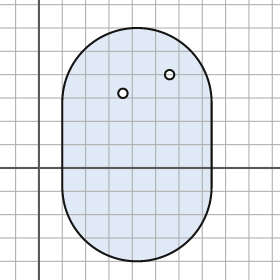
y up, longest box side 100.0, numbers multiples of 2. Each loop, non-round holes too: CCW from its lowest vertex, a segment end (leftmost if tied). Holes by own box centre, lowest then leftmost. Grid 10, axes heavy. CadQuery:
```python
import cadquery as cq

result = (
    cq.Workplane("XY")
    .moveTo(10.0, -8.0)
    .threePointArc((42.0, -40.0), (74.0, -8.0))
    .lineTo(74.0, 28.0)
    .threePointArc((42.0, 60.0), (10.0, 28.0))
    .close()
    .moveTo(36.0, 32.0)
    .circle(2.0)
    .moveTo(56.0, 40.0)
    .circle(2.0)
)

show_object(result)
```